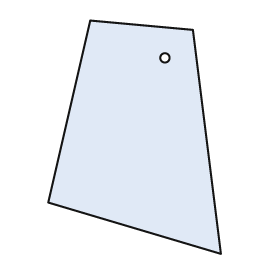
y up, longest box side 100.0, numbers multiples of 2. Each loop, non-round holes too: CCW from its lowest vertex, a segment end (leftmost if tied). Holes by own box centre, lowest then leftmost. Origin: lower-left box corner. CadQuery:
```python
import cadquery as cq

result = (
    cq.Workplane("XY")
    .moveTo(74.0, 0.0)
    .lineTo(62.0, 96.0)
    .lineTo(18.0, 100.0)
    .lineTo(0.0, 22.0)
    .close()
    .moveTo(50.0, 84.0)
    .circle(2.0)
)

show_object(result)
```